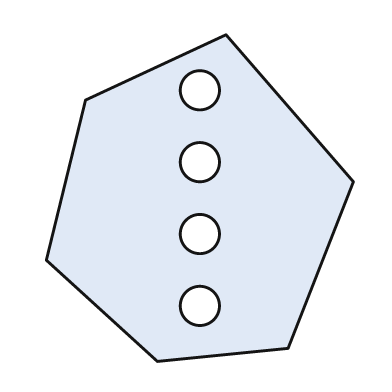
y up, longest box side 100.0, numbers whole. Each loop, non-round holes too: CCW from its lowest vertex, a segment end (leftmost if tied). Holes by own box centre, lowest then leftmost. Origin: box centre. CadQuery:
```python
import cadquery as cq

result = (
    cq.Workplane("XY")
    .moveTo(-13.0, -50.0)
    .lineTo(27.0, -46.0)
    .lineTo(47.0, 5.0)
    .lineTo(8.0, 50.0)
    .lineTo(-35.0, 30.0)
    .lineTo(-47.0, -19.0)
    .close()
    .moveTo(0.0, -33.0)
    .circle(6.0)
    .moveTo(0.0, -11.0)
    .circle(6.0)
    .moveTo(0.0, 11.0)
    .circle(6.0)
    .moveTo(0.0, 33.0)
    .circle(6.0)
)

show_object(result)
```